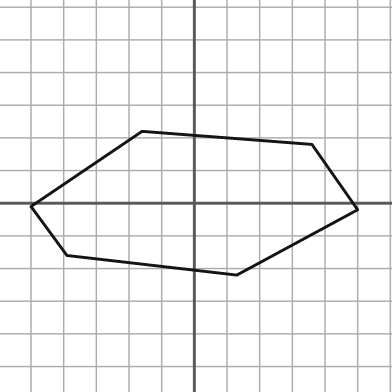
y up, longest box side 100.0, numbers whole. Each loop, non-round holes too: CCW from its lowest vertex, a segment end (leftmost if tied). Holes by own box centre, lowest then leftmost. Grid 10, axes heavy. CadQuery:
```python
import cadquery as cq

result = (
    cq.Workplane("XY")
    .moveTo(13.0, -22.0)
    .lineTo(50.0, -2.0)
    .lineTo(36.0, 18.0)
    .lineTo(-16.0, 22.0)
    .lineTo(-50.0, -1.0)
    .lineTo(-39.0, -16.0)
    .close()
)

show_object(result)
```